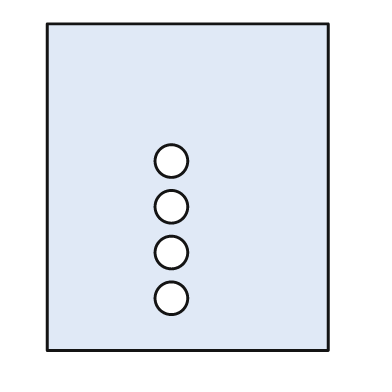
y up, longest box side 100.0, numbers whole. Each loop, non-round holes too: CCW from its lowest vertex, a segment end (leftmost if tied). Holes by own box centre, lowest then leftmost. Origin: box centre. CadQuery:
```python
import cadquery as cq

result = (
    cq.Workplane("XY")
    .moveTo(-43.0, -50.0)
    .lineTo(43.0, -50.0)
    .lineTo(43.0, 50.0)
    .lineTo(-43.0, 50.0)
    .close()
    .moveTo(-5.0, -34.0)
    .circle(5.0)
    .moveTo(-5.0, -20.0)
    .circle(5.0)
    .moveTo(-5.0, -6.0)
    .circle(5.0)
    .moveTo(-5.0, 8.0)
    .circle(5.0)
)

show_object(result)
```